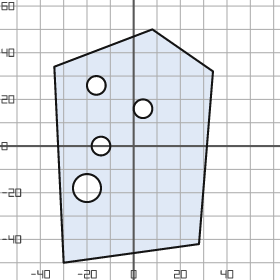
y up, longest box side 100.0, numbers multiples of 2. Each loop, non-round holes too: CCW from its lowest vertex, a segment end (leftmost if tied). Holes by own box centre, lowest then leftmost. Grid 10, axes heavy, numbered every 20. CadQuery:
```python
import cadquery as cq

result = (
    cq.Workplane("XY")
    .moveTo(-30.0, -50.0)
    .lineTo(28.0, -42.0)
    .lineTo(34.0, 32.0)
    .lineTo(8.0, 50.0)
    .lineTo(-34.0, 34.0)
    .close()
    .moveTo(-20.0, -18.0)
    .circle(6.0)
    .moveTo(-14.0, 0.0)
    .circle(4.0)
    .moveTo(4.0, 16.0)
    .circle(4.0)
    .moveTo(-16.0, 26.0)
    .circle(4.0)
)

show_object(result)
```